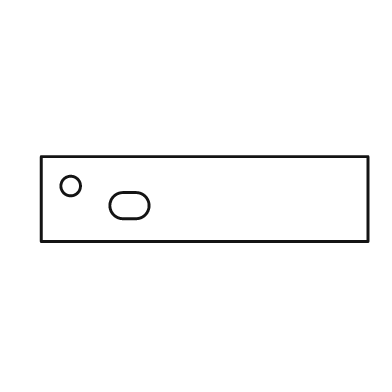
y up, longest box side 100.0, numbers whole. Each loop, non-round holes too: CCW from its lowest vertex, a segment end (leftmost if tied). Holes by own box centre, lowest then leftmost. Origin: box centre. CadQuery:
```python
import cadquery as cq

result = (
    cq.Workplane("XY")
    .moveTo(-50.0, -13.0)
    .lineTo(50.0, -13.0)
    .lineTo(50.0, 13.0)
    .lineTo(-50.0, 13.0)
    .close()
    .moveTo(-25.0, -6.0)
    .lineTo(-21.0, -6.0)
    .threePointArc((-17.0, -2.0), (-21.0, 2.0))
    .lineTo(-25.0, 2.0)
    .threePointArc((-29.0, -2.0), (-25.0, -6.0))
    .close()
    .moveTo(-41.0, 4.0)
    .circle(3.0)
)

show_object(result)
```